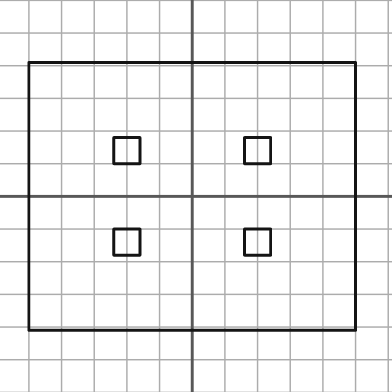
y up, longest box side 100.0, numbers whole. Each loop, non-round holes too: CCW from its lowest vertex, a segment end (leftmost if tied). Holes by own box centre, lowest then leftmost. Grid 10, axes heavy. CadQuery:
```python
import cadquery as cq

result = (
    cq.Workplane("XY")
    .moveTo(-50.0, -41.0)
    .lineTo(50.0, -41.0)
    .lineTo(50.0, 41.0)
    .lineTo(-50.0, 41.0)
    .close()
    .moveTo(-24.0, -18.0)
    .lineTo(-16.0, -18.0)
    .lineTo(-16.0, -10.0)
    .lineTo(-24.0, -10.0)
    .close()
    .moveTo(16.0, -18.0)
    .lineTo(24.0, -18.0)
    .lineTo(24.0, -10.0)
    .lineTo(16.0, -10.0)
    .close()
    .moveTo(-24.0, 10.0)
    .lineTo(-16.0, 10.0)
    .lineTo(-16.0, 18.0)
    .lineTo(-24.0, 18.0)
    .close()
    .moveTo(16.0, 10.0)
    .lineTo(24.0, 10.0)
    .lineTo(24.0, 18.0)
    .lineTo(16.0, 18.0)
    .close()
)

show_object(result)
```